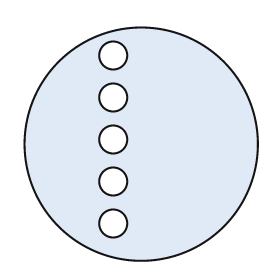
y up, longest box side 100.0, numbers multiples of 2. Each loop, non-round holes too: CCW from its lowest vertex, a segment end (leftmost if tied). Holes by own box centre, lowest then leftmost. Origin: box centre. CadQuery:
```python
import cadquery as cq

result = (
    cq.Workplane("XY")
    .moveTo(0.0, 0.0)
    .circle(50.0)
    .moveTo(-12.0, -34.0)
    .circle(6.0)
    .moveTo(-12.0, -16.0)
    .circle(6.0)
    .moveTo(-12.0, 2.0)
    .circle(6.0)
    .moveTo(-12.0, 20.0)
    .circle(6.0)
    .moveTo(-12.0, 38.0)
    .circle(6.0)
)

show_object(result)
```